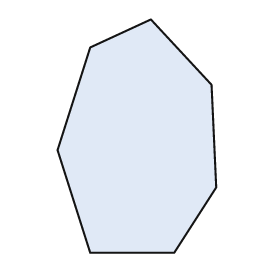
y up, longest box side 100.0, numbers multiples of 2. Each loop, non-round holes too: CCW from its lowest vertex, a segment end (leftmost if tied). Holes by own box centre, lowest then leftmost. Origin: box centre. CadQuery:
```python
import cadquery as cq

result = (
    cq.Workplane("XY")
    .moveTo(-20.0, -50.0)
    .lineTo(16.0, -50.0)
    .lineTo(34.0, -22.0)
    .lineTo(32.0, 22.0)
    .lineTo(6.0, 50.0)
    .lineTo(-20.0, 38.0)
    .lineTo(-34.0, -6.0)
    .close()
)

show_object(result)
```